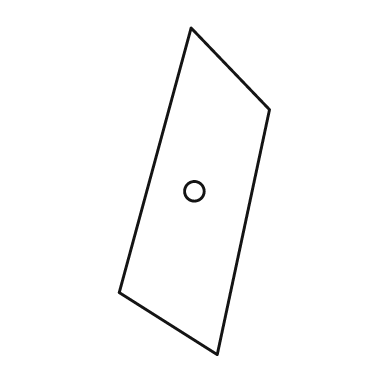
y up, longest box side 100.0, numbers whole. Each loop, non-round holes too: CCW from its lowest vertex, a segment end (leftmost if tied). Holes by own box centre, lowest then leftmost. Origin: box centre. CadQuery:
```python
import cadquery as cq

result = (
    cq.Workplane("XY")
    .moveTo(7.0, -50.0)
    .lineTo(23.0, 25.0)
    .lineTo(-1.0, 50.0)
    .lineTo(-23.0, -31.0)
    .close()
    .moveTo(0.0, 0.0)
    .circle(3.0)
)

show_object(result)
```